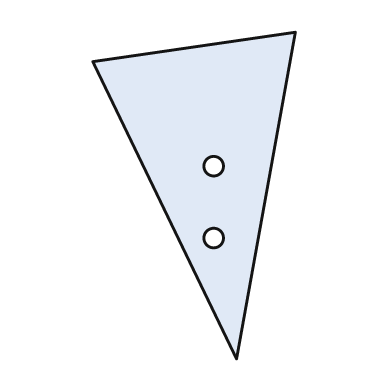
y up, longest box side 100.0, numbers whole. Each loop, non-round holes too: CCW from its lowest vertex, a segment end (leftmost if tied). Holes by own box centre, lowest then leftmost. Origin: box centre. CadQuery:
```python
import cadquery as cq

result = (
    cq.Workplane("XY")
    .moveTo(13.0, -50.0)
    .lineTo(31.0, 50.0)
    .lineTo(-31.0, 41.0)
    .close()
    .moveTo(6.0, -13.0)
    .circle(3.0)
    .moveTo(6.0, 9.0)
    .circle(3.0)
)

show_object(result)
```